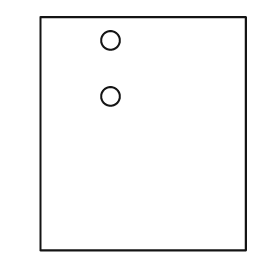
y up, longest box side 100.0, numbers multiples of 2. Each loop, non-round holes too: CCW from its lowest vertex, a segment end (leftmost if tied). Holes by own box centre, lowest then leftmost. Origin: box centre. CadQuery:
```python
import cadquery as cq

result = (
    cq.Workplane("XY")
    .moveTo(-44.0, -50.0)
    .lineTo(44.0, -50.0)
    .lineTo(44.0, 50.0)
    .lineTo(-44.0, 50.0)
    .close()
    .moveTo(-14.0, 16.0)
    .circle(4.0)
    .moveTo(-14.0, 40.0)
    .circle(4.0)
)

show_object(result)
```